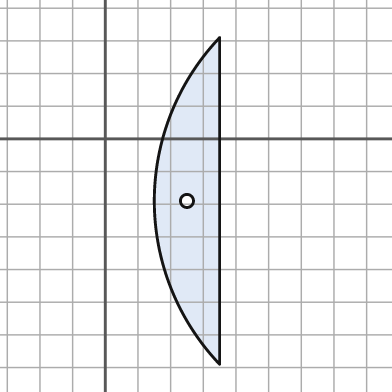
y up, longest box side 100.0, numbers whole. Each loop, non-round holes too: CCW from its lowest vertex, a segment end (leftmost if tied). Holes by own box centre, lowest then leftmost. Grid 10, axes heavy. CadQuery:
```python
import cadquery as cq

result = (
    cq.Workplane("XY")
    .moveTo(35.0, -69.0)
    .lineTo(35.0, 31.0)
    .threePointArc((15.0, -19.0), (35.0, -69.0))
    .close()
    .moveTo(25.0, -19.0)
    .circle(2.0)
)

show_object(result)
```